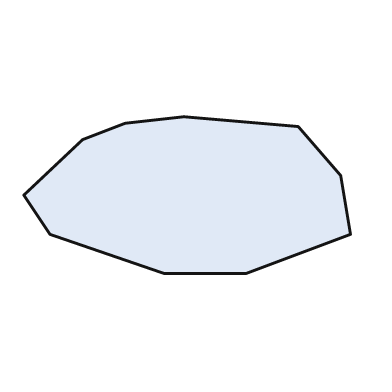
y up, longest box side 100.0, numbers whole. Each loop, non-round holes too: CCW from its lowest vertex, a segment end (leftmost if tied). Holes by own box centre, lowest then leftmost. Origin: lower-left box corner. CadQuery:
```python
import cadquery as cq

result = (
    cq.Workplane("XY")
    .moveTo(43.0, 0.0)
    .lineTo(68.0, 0.0)
    .lineTo(100.0, 12.0)
    .lineTo(97.0, 30.0)
    .lineTo(84.0, 45.0)
    .lineTo(49.0, 48.0)
    .lineTo(31.0, 46.0)
    .lineTo(18.0, 41.0)
    .lineTo(0.0, 24.0)
    .lineTo(8.0, 12.0)
    .close()
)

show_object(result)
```